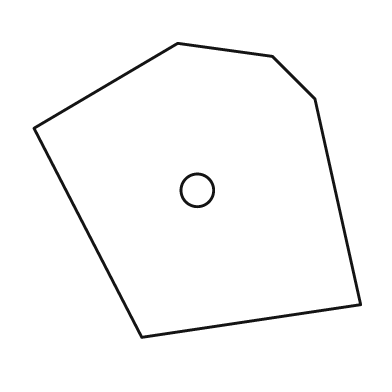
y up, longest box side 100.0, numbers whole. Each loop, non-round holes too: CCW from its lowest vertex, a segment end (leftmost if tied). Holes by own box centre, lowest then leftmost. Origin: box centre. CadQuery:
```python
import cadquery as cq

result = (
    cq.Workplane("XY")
    .moveTo(-17.0, -45.0)
    .lineTo(50.0, -35.0)
    .lineTo(36.0, 28.0)
    .lineTo(23.0, 41.0)
    .lineTo(-6.0, 45.0)
    .lineTo(-50.0, 19.0)
    .close()
    .moveTo(0.0, 0.0)
    .circle(5.0)
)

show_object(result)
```